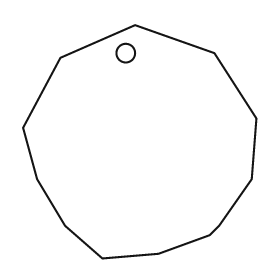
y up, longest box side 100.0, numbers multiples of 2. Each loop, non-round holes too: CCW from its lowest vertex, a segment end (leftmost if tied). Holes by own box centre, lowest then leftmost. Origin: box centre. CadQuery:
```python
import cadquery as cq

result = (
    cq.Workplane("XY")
    .moveTo(-16.0, -50.0)
    .lineTo(8.0, -48.0)
    .lineTo(30.0, -40.0)
    .lineTo(34.0, -36.0)
    .lineTo(48.0, -16.0)
    .lineTo(50.0, 10.0)
    .lineTo(32.0, 38.0)
    .lineTo(-2.0, 50.0)
    .lineTo(-34.0, 36.0)
    .lineTo(-50.0, 6.0)
    .lineTo(-44.0, -16.0)
    .lineTo(-32.0, -36.0)
    .close()
    .moveTo(-6.0, 38.0)
    .circle(4.0)
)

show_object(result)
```